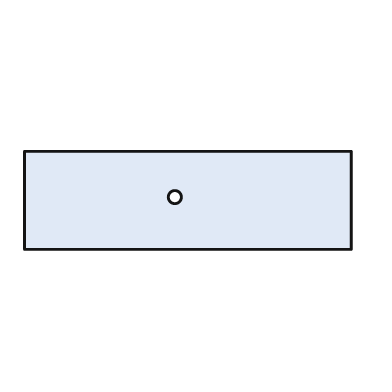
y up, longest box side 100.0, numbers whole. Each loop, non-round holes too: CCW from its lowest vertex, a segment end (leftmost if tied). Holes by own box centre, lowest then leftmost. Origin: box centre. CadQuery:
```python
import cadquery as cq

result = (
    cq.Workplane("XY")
    .moveTo(-50.0, -15.0)
    .lineTo(50.0, -15.0)
    .lineTo(50.0, 15.0)
    .lineTo(-50.0, 15.0)
    .close()
    .moveTo(-4.0, 1.0)
    .circle(2.0)
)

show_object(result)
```